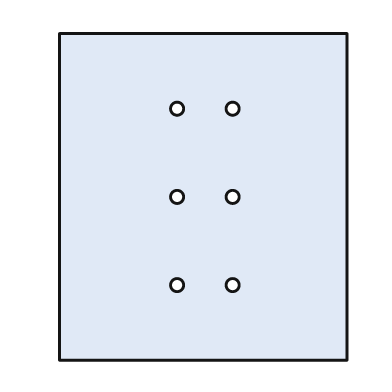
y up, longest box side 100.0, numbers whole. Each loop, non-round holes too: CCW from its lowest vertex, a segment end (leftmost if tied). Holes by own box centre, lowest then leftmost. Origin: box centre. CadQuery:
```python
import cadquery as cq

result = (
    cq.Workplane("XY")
    .moveTo(-44.0, -50.0)
    .lineTo(44.0, -50.0)
    .lineTo(44.0, 50.0)
    .lineTo(-44.0, 50.0)
    .close()
    .moveTo(-8.0, -27.0)
    .circle(2.0)
    .moveTo(9.0, -27.0)
    .circle(2.0)
    .moveTo(-8.0, 0.0)
    .circle(2.0)
    .moveTo(9.0, 0.0)
    .circle(2.0)
    .moveTo(-8.0, 27.0)
    .circle(2.0)
    .moveTo(9.0, 27.0)
    .circle(2.0)
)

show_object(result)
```